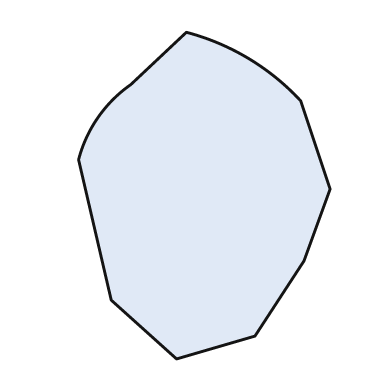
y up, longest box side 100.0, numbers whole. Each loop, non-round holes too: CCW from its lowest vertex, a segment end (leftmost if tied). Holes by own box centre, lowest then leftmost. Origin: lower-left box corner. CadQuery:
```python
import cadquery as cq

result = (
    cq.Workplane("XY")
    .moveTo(30.0, 0.0)
    .lineTo(54.0, 7.0)
    .lineTo(69.0, 30.0)
    .lineTo(77.0, 52.0)
    .lineTo(68.0, 79.0)
    .threePointArc((52.0, 92.0), (33.0, 100.0))
    .lineTo(16.0, 84.0)
    .threePointArc((6.0, 74.0), (0.0, 61.0))
    .lineTo(10.0, 18.0)
    .close()
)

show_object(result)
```